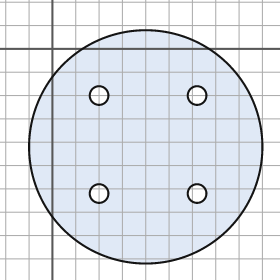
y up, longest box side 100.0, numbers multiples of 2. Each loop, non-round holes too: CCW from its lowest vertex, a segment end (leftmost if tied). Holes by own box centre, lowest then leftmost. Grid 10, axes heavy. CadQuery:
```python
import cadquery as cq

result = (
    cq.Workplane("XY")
    .moveTo(40.0, -42.0)
    .circle(50.0)
    .moveTo(20.0, -62.0)
    .circle(4.0)
    .moveTo(62.0, -62.0)
    .circle(4.0)
    .moveTo(20.0, -20.0)
    .circle(4.0)
    .moveTo(62.0, -20.0)
    .circle(4.0)
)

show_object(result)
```